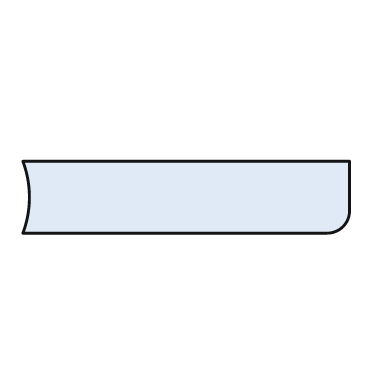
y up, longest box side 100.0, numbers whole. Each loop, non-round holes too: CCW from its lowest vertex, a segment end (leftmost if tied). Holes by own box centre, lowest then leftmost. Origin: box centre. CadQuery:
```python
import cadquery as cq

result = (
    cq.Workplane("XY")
    .moveTo(-50.0, -11.0)
    .lineTo(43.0, -11.0)
    .threePointArc((48.0, -9.0), (50.0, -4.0))
    .lineTo(50.0, 11.0)
    .lineTo(-50.0, 11.0)
    .threePointArc((-48.0, 0.0), (-50.0, -11.0))
    .close()
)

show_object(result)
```